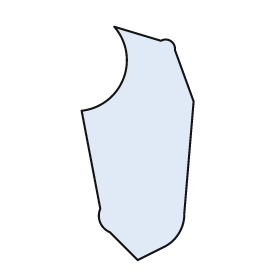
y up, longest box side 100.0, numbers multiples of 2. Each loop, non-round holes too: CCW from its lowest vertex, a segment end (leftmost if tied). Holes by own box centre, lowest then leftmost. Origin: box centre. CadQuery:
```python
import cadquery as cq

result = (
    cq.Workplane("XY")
    .moveTo(0.0, -50.0)
    .lineTo(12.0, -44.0)
    .threePointArc((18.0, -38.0), (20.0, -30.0))
    .lineTo(24.0, 18.0)
    .lineTo(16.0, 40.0)
    .threePointArc((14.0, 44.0), (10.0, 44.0))
    .lineTo(-10.0, 50.0)
    .threePointArc((-6.0, 28.0), (-24.0, 14.0))
    .lineTo(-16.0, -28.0)
    .threePointArc((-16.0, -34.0), (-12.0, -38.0))
    .close()
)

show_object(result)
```